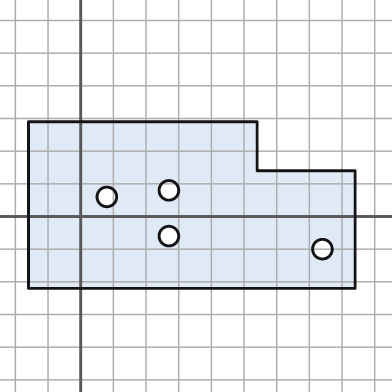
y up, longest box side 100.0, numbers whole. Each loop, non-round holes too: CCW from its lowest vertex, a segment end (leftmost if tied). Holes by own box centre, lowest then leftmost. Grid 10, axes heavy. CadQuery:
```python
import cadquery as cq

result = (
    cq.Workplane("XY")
    .moveTo(-16.0, -22.0)
    .lineTo(84.0, -22.0)
    .lineTo(84.0, 14.0)
    .lineTo(54.0, 14.0)
    .lineTo(54.0, 29.0)
    .lineTo(-16.0, 29.0)
    .close()
    .moveTo(74.0, -10.0)
    .circle(3.0)
    .moveTo(27.0, -6.0)
    .circle(3.0)
    .moveTo(8.0, 6.0)
    .circle(3.0)
    .moveTo(27.0, 8.0)
    .circle(3.0)
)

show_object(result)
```